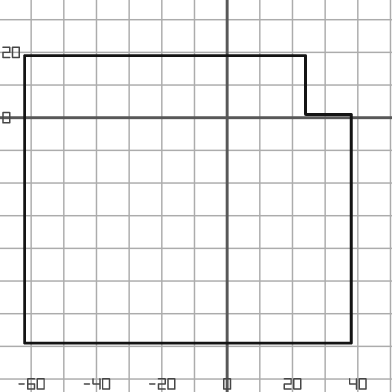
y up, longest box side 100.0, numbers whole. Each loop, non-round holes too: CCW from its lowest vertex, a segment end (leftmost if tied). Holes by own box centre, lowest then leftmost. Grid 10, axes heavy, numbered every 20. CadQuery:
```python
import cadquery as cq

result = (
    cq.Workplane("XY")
    .moveTo(-62.0, -69.0)
    .lineTo(38.0, -69.0)
    .lineTo(38.0, 1.0)
    .lineTo(24.0, 1.0)
    .lineTo(24.0, 19.0)
    .lineTo(-62.0, 19.0)
    .close()
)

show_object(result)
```